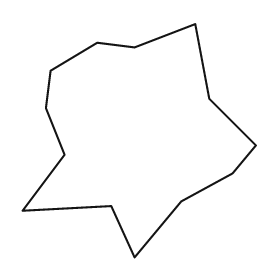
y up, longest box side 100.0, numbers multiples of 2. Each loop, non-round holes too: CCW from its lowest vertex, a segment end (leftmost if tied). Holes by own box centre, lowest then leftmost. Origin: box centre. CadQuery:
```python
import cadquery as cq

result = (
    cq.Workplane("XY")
    .moveTo(-2.0, -50.0)
    .lineTo(18.0, -26.0)
    .lineTo(40.0, -14.0)
    .lineTo(50.0, -2.0)
    .lineTo(30.0, 18.0)
    .lineTo(24.0, 50.0)
    .lineTo(-2.0, 40.0)
    .lineTo(-18.0, 42.0)
    .lineTo(-38.0, 30.0)
    .lineTo(-40.0, 14.0)
    .lineTo(-32.0, -6.0)
    .lineTo(-50.0, -30.0)
    .lineTo(-12.0, -28.0)
    .close()
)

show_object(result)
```